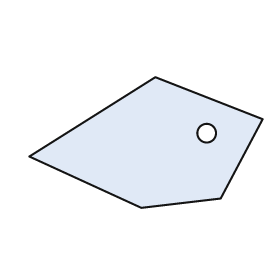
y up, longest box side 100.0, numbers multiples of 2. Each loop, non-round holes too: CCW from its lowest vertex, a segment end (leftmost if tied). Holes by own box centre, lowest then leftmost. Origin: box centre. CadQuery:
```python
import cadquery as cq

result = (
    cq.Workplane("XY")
    .moveTo(-2.0, -28.0)
    .lineTo(32.0, -24.0)
    .lineTo(50.0, 10.0)
    .lineTo(4.0, 28.0)
    .lineTo(-50.0, -6.0)
    .close()
    .moveTo(26.0, 4.0)
    .circle(4.0)
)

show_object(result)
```